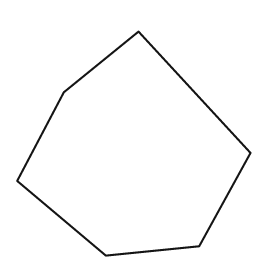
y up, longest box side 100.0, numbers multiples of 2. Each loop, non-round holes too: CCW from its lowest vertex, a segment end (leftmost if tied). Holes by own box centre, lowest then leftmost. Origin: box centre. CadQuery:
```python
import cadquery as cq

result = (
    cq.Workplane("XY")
    .moveTo(-12.0, -48.0)
    .lineTo(28.0, -44.0)
    .lineTo(50.0, -4.0)
    .lineTo(2.0, 48.0)
    .lineTo(-30.0, 22.0)
    .lineTo(-50.0, -16.0)
    .close()
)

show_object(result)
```